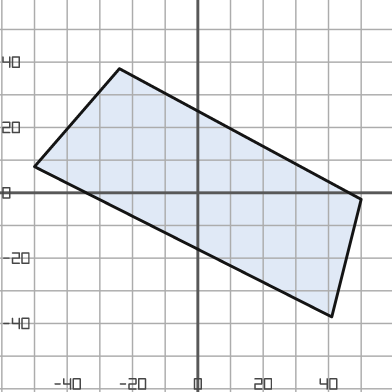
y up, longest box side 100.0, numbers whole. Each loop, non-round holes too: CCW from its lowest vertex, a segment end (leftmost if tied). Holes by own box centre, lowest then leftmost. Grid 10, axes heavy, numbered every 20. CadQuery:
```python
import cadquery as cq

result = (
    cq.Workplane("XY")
    .moveTo(41.0, -38.0)
    .lineTo(50.0, -2.0)
    .lineTo(-24.0, 38.0)
    .lineTo(-50.0, 8.0)
    .close()
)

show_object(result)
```